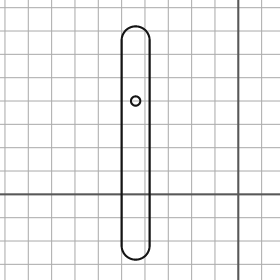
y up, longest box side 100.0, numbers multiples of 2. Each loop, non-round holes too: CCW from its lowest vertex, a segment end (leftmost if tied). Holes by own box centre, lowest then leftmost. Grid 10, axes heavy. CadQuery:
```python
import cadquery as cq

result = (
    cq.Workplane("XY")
    .moveTo(-50.0, -22.0)
    .threePointArc((-44.0, -28.0), (-38.0, -22.0))
    .lineTo(-38.0, 66.0)
    .threePointArc((-44.0, 72.0), (-50.0, 66.0))
    .close()
    .moveTo(-44.0, 40.0)
    .circle(2.0)
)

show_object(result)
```